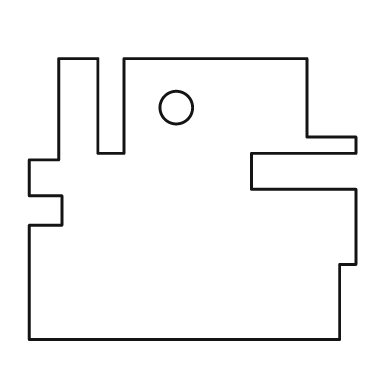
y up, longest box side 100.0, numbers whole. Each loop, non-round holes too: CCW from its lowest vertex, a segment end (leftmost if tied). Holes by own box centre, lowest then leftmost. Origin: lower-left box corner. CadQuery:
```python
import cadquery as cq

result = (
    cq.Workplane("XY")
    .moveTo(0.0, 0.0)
    .lineTo(95.0, 0.0)
    .lineTo(95.0, 23.0)
    .lineTo(100.0, 23.0)
    .lineTo(100.0, 46.0)
    .lineTo(68.0, 46.0)
    .lineTo(68.0, 57.0)
    .lineTo(100.0, 57.0)
    .lineTo(100.0, 62.0)
    .lineTo(85.0, 62.0)
    .lineTo(85.0, 86.0)
    .lineTo(29.0, 86.0)
    .lineTo(29.0, 57.0)
    .lineTo(21.0, 57.0)
    .lineTo(21.0, 86.0)
    .lineTo(9.0, 86.0)
    .lineTo(9.0, 55.0)
    .lineTo(0.0, 55.0)
    .lineTo(0.0, 44.0)
    .lineTo(10.0, 44.0)
    .lineTo(10.0, 35.0)
    .lineTo(0.0, 35.0)
    .close()
    .moveTo(45.0, 71.0)
    .circle(5.0)
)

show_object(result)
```